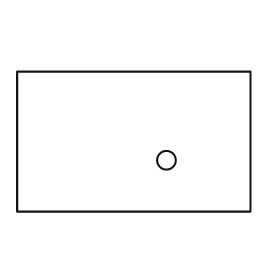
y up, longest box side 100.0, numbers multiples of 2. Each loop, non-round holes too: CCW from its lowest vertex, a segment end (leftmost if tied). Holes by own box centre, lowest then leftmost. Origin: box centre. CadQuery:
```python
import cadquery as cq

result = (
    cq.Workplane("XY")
    .moveTo(-50.0, -30.0)
    .lineTo(50.0, -30.0)
    .lineTo(50.0, 30.0)
    .lineTo(-50.0, 30.0)
    .close()
    .moveTo(14.0, -8.0)
    .circle(4.0)
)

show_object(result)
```